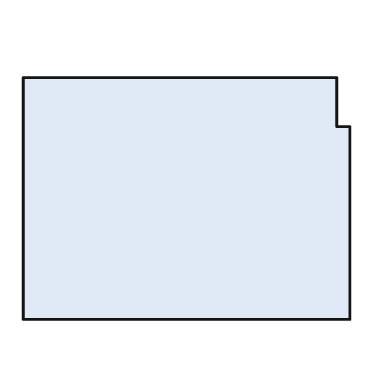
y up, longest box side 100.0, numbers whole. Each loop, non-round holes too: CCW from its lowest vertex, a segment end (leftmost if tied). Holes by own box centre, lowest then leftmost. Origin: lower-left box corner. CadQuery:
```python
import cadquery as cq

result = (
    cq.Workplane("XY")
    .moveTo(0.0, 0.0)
    .lineTo(100.0, 0.0)
    .lineTo(100.0, 59.0)
    .lineTo(96.0, 59.0)
    .lineTo(96.0, 74.0)
    .lineTo(0.0, 74.0)
    .close()
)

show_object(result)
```